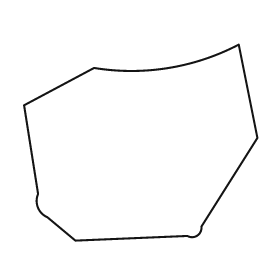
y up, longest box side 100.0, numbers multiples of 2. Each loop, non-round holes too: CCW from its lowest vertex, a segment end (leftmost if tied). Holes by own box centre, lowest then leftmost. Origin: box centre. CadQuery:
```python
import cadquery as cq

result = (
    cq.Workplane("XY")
    .moveTo(-28.0, -42.0)
    .lineTo(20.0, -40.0)
    .threePointArc((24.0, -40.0), (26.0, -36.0))
    .lineTo(50.0, 2.0)
    .lineTo(42.0, 42.0)
    .threePointArc((12.0, 32.0), (-20.0, 32.0))
    .lineTo(-50.0, 16.0)
    .lineTo(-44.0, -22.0)
    .threePointArc((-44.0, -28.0), (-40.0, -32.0))
    .close()
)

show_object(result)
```